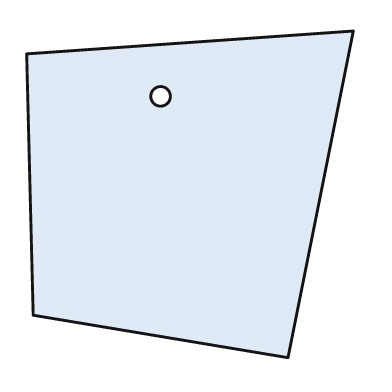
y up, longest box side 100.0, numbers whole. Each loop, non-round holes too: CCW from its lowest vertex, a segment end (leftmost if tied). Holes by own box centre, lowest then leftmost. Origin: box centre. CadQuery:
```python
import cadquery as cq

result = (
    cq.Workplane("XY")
    .moveTo(30.0, -50.0)
    .lineTo(50.0, 50.0)
    .lineTo(-50.0, 43.0)
    .lineTo(-48.0, -37.0)
    .close()
    .moveTo(-9.0, 30.0)
    .circle(3.0)
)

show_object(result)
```